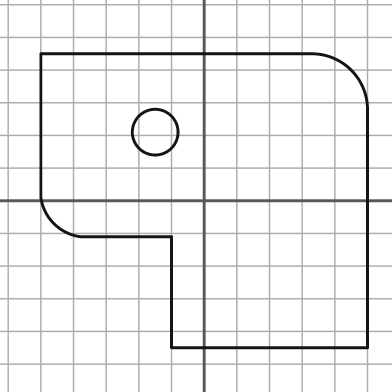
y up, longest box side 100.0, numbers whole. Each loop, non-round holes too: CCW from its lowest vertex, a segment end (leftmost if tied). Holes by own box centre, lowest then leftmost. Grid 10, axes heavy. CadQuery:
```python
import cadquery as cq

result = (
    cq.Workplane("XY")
    .moveTo(-10.0, -45.0)
    .lineTo(50.0, -45.0)
    .lineTo(50.0, 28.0)
    .threePointArc((45.0, 40.0), (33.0, 45.0))
    .lineTo(-50.0, 45.0)
    .lineTo(-50.0, 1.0)
    .threePointArc((-46.0, -7.0), (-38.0, -11.0))
    .lineTo(-10.0, -11.0)
    .close()
    .moveTo(-15.0, 21.0)
    .circle(7.0)
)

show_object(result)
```